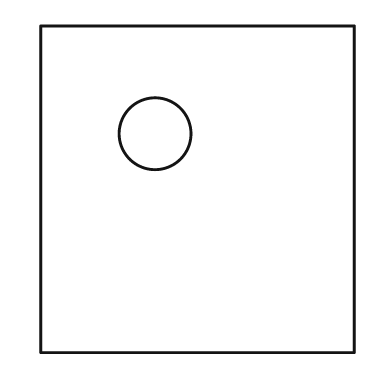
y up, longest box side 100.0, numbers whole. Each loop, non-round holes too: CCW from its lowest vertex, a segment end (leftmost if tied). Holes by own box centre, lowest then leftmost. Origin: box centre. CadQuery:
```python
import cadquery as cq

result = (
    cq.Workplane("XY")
    .moveTo(-48.0, -50.0)
    .lineTo(48.0, -50.0)
    .lineTo(48.0, 50.0)
    .lineTo(-48.0, 50.0)
    .close()
    .moveTo(-13.0, 17.0)
    .circle(11.0)
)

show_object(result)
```